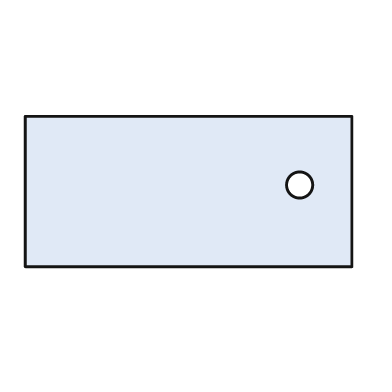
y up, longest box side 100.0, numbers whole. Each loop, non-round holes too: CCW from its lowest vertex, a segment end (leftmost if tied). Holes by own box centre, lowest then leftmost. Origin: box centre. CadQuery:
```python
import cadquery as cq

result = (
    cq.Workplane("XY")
    .moveTo(-50.0, -23.0)
    .lineTo(50.0, -23.0)
    .lineTo(50.0, 23.0)
    .lineTo(-50.0, 23.0)
    .close()
    .moveTo(34.0, 2.0)
    .circle(4.0)
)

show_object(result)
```